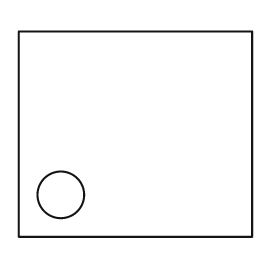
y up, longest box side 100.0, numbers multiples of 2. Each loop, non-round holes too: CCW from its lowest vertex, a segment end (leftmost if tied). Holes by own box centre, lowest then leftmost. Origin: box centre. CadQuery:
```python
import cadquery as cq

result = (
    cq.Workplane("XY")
    .moveTo(-50.0, -44.0)
    .lineTo(50.0, -44.0)
    .lineTo(50.0, 44.0)
    .lineTo(-50.0, 44.0)
    .close()
    .moveTo(-32.0, -26.0)
    .circle(10.0)
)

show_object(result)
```